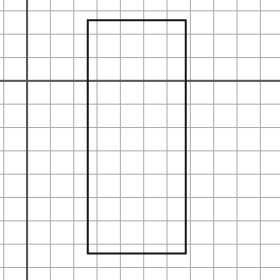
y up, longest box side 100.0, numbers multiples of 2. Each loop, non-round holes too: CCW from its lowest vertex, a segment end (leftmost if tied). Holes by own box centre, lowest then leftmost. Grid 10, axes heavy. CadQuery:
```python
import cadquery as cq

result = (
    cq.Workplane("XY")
    .moveTo(26.0, -74.0)
    .lineTo(68.0, -74.0)
    .lineTo(68.0, 26.0)
    .lineTo(26.0, 26.0)
    .close()
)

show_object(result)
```